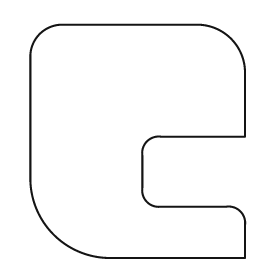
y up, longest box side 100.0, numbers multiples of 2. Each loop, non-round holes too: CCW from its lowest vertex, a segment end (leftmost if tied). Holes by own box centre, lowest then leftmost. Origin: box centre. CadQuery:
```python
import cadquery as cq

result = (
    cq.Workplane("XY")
    .moveTo(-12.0, -50.0)
    .lineTo(46.0, -50.0)
    .lineTo(46.0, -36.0)
    .threePointArc((44.0, -30.0), (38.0, -28.0))
    .lineTo(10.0, -28.0)
    .threePointArc((4.0, -26.0), (2.0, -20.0))
    .lineTo(2.0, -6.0)
    .threePointArc((4.0, 0.0), (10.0, 2.0))
    .lineTo(46.0, 2.0)
    .lineTo(46.0, 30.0)
    .threePointArc((40.0, 44.0), (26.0, 50.0))
    .lineTo(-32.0, 50.0)
    .threePointArc((-42.0, 46.0), (-46.0, 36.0))
    .lineTo(-46.0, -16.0)
    .threePointArc((-36.0, -40.0), (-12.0, -50.0))
    .close()
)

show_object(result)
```